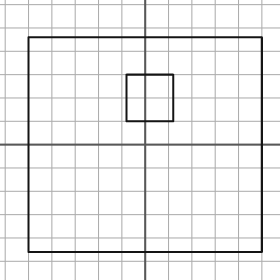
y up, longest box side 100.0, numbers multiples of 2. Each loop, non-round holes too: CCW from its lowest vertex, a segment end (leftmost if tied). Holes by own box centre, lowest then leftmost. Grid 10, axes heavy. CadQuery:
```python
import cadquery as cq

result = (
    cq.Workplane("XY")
    .moveTo(-50.0, -46.0)
    .lineTo(50.0, -46.0)
    .lineTo(50.0, 46.0)
    .lineTo(-50.0, 46.0)
    .close()
    .moveTo(-8.0, 10.0)
    .lineTo(12.0, 10.0)
    .lineTo(12.0, 30.0)
    .lineTo(-8.0, 30.0)
    .close()
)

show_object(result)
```